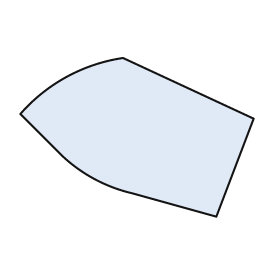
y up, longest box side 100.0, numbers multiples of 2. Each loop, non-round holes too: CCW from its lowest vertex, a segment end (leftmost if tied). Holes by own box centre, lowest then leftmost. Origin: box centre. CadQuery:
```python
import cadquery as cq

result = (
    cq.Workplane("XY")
    .moveTo(34.0, -34.0)
    .lineTo(50.0, 8.0)
    .lineTo(-6.0, 34.0)
    .threePointArc((-30.0, 26.0), (-50.0, 10.0))
    .lineTo(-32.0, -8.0)
    .threePointArc((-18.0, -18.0), (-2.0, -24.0))
    .close()
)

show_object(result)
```